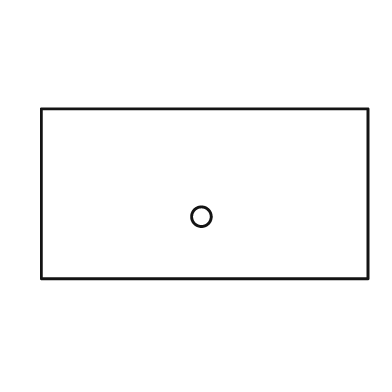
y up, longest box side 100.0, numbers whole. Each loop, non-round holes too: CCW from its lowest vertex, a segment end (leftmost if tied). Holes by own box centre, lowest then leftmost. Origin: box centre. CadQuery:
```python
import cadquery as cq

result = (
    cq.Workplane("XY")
    .moveTo(-50.0, -26.0)
    .lineTo(50.0, -26.0)
    .lineTo(50.0, 26.0)
    .lineTo(-50.0, 26.0)
    .close()
    .moveTo(-1.0, -7.0)
    .circle(3.0)
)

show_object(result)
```